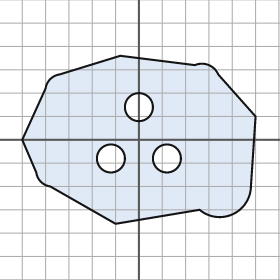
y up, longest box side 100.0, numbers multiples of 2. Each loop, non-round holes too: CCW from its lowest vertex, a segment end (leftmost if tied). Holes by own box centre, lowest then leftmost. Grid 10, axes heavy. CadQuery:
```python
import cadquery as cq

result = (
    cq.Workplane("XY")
    .moveTo(-10.0, -36.0)
    .lineTo(26.0, -30.0)
    .threePointArc((40.0, -32.0), (48.0, -20.0))
    .lineTo(50.0, 10.0)
    .lineTo(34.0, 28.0)
    .threePointArc((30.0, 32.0), (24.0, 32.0))
    .lineTo(-8.0, 36.0)
    .lineTo(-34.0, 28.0)
    .threePointArc((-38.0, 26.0), (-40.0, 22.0))
    .lineTo(-50.0, 0.0)
    .lineTo(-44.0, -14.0)
    .threePointArc((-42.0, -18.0), (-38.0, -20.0))
    .close()
    .moveTo(-12.0, -8.0)
    .circle(6.0)
    .moveTo(12.0, -8.0)
    .circle(6.0)
    .moveTo(0.0, 14.0)
    .circle(6.0)
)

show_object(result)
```